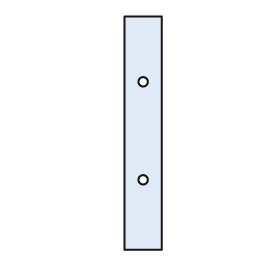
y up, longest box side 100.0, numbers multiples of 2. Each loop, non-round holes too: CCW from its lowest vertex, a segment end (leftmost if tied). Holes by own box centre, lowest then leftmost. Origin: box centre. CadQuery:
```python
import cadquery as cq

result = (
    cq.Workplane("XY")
    .moveTo(-8.0, -50.0)
    .lineTo(8.0, -50.0)
    .lineTo(8.0, 50.0)
    .lineTo(-8.0, 50.0)
    .close()
    .moveTo(0.0, -20.0)
    .circle(2.0)
    .moveTo(0.0, 22.0)
    .circle(2.0)
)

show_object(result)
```